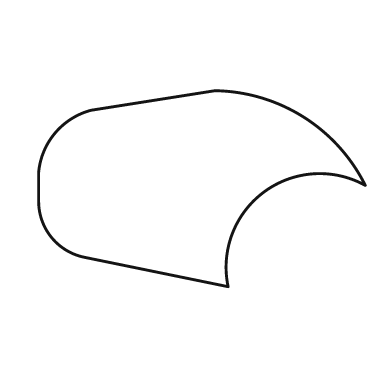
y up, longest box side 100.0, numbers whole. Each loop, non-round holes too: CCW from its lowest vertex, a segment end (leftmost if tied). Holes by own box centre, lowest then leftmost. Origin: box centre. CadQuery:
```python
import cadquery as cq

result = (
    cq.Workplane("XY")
    .moveTo(8.0, -30.0)
    .threePointArc((19.0, -1.0), (50.0, 1.0))
    .threePointArc((31.0, 22.0), (4.0, 30.0))
    .lineTo(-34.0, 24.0)
    .threePointArc((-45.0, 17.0), (-50.0, 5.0))
    .lineTo(-50.0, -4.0)
    .threePointArc((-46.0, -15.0), (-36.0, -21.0))
    .close()
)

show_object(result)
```